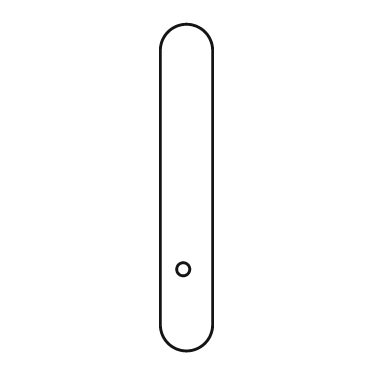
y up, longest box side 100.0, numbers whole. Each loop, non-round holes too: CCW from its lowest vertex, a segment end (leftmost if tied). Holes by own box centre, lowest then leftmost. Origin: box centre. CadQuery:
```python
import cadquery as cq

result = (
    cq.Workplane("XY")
    .moveTo(-8.0, -42.0)
    .threePointArc((0.0, -50.0), (8.0, -42.0))
    .lineTo(8.0, 42.0)
    .threePointArc((0.0, 50.0), (-8.0, 42.0))
    .close()
    .moveTo(-1.0, -25.0)
    .circle(2.0)
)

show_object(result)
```